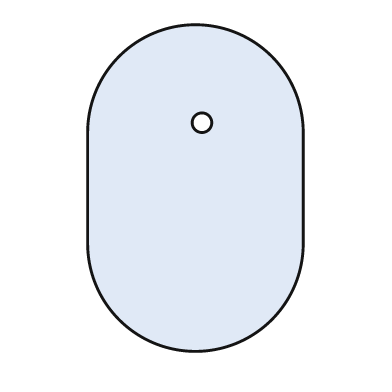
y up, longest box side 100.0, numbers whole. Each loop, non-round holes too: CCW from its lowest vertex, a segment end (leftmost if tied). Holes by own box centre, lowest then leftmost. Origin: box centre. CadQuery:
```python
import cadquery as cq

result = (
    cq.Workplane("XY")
    .moveTo(-33.0, -17.0)
    .threePointArc((0.0, -50.0), (33.0, -17.0))
    .lineTo(33.0, 17.0)
    .threePointArc((0.0, 50.0), (-33.0, 17.0))
    .close()
    .moveTo(2.0, 20.0)
    .circle(3.0)
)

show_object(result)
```